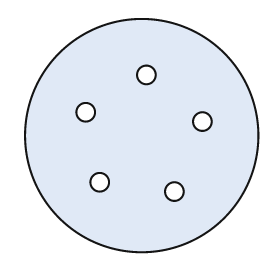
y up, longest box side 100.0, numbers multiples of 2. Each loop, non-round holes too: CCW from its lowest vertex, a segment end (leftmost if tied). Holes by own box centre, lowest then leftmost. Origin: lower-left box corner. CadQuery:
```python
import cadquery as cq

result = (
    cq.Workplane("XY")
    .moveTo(50.0, 50.0)
    .circle(50.0)
    .moveTo(64.0, 26.0)
    .circle(4.0)
    .moveTo(32.0, 30.0)
    .circle(4.0)
    .moveTo(76.0, 56.0)
    .circle(4.0)
    .moveTo(26.0, 60.0)
    .circle(4.0)
    .moveTo(52.0, 76.0)
    .circle(4.0)
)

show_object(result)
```